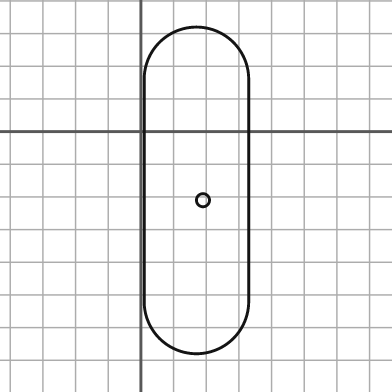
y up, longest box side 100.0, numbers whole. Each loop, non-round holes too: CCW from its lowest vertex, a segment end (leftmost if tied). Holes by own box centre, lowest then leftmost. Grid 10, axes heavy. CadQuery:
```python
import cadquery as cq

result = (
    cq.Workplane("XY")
    .moveTo(1.0, -52.0)
    .threePointArc((17.0, -68.0), (33.0, -52.0))
    .lineTo(33.0, 16.0)
    .threePointArc((17.0, 32.0), (1.0, 16.0))
    .close()
    .moveTo(19.0, -21.0)
    .circle(2.0)
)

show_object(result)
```